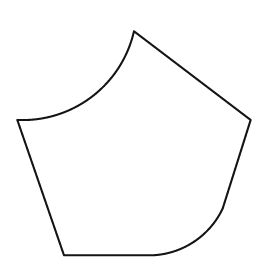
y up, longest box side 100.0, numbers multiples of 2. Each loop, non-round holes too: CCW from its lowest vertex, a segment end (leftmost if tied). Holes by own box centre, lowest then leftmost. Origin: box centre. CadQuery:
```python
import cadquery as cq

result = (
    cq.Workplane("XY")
    .moveTo(-30.0, -48.0)
    .lineTo(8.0, -48.0)
    .threePointArc((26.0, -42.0), (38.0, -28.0))
    .lineTo(50.0, 10.0)
    .lineTo(0.0, 48.0)
    .threePointArc((-18.0, 20.0), (-50.0, 10.0))
    .close()
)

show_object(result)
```